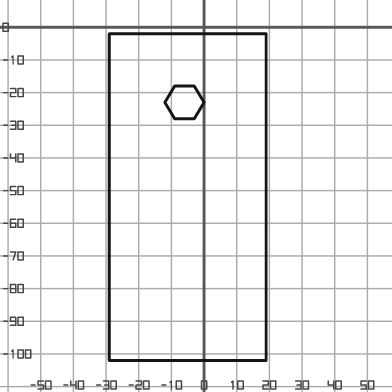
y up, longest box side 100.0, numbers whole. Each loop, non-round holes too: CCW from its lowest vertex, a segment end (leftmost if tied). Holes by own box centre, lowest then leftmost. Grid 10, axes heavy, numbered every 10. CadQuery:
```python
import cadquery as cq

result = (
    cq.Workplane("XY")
    .moveTo(-29.0, -102.0)
    .lineTo(19.0, -102.0)
    .lineTo(19.0, -2.0)
    .lineTo(-29.0, -2.0)
    .close()
    .moveTo(-9.0, -28.0)
    .lineTo(-3.0, -28.0)
    .lineTo(0.0, -23.0)
    .lineTo(-3.0, -18.0)
    .lineTo(-9.0, -18.0)
    .lineTo(-12.0, -23.0)
    .close()
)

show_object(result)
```